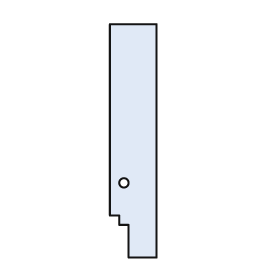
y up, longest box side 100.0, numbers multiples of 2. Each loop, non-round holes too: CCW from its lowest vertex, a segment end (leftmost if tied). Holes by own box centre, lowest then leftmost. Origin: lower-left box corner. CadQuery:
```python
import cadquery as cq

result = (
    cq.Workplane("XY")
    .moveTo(8.0, 0.0)
    .lineTo(20.0, 0.0)
    .lineTo(20.0, 100.0)
    .lineTo(0.0, 100.0)
    .lineTo(0.0, 18.0)
    .lineTo(4.0, 18.0)
    .lineTo(4.0, 14.0)
    .lineTo(8.0, 14.0)
    .close()
    .moveTo(6.0, 32.0)
    .circle(2.0)
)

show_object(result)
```